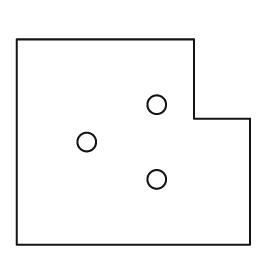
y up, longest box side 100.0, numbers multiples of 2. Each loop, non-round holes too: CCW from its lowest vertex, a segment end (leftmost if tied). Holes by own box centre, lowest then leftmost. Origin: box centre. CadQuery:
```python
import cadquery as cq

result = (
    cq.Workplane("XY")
    .moveTo(-50.0, -44.0)
    .lineTo(50.0, -44.0)
    .lineTo(50.0, 10.0)
    .lineTo(26.0, 10.0)
    .lineTo(26.0, 44.0)
    .lineTo(-50.0, 44.0)
    .close()
    .moveTo(10.0, -16.0)
    .circle(4.0)
    .moveTo(-20.0, 0.0)
    .circle(4.0)
    .moveTo(10.0, 16.0)
    .circle(4.0)
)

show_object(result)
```